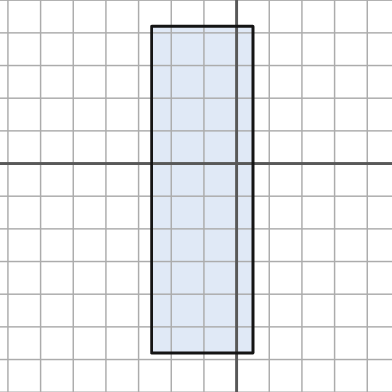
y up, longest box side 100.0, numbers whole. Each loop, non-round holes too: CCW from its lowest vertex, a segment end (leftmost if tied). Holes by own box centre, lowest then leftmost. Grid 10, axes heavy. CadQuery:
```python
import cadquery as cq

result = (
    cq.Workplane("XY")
    .moveTo(-26.0, -58.0)
    .lineTo(5.0, -58.0)
    .lineTo(5.0, 42.0)
    .lineTo(-26.0, 42.0)
    .close()
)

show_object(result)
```